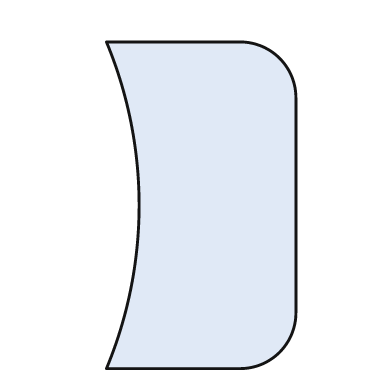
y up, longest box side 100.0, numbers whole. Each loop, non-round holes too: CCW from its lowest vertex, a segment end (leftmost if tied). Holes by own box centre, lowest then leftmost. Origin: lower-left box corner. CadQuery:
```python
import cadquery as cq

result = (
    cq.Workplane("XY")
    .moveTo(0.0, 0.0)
    .lineTo(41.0, 0.0)
    .threePointArc((53.0, 5.0), (58.0, 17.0))
    .lineTo(58.0, 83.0)
    .threePointArc((53.0, 95.0), (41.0, 100.0))
    .lineTo(0.0, 100.0)
    .threePointArc((10.0, 50.0), (0.0, 0.0))
    .close()
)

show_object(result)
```